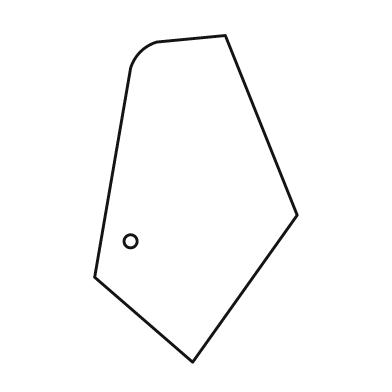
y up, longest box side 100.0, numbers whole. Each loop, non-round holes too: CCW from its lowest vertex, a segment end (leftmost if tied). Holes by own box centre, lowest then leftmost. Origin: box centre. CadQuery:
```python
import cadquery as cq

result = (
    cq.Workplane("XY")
    .moveTo(-1.0, -50.0)
    .lineTo(31.0, -5.0)
    .lineTo(9.0, 50.0)
    .lineTo(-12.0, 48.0)
    .threePointArc((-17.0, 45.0), (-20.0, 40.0))
    .lineTo(-31.0, -24.0)
    .close()
    .moveTo(-20.0, -13.0)
    .circle(2.0)
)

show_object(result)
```